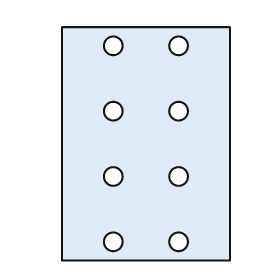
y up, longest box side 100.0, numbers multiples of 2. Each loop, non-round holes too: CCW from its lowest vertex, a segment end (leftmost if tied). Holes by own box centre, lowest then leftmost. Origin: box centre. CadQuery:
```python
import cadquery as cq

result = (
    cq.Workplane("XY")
    .moveTo(-36.0, -50.0)
    .lineTo(36.0, -50.0)
    .lineTo(36.0, 50.0)
    .lineTo(-36.0, 50.0)
    .close()
    .moveTo(-14.0, -42.0)
    .circle(4.0)
    .moveTo(14.0, -42.0)
    .circle(4.0)
    .moveTo(-14.0, -14.0)
    .circle(4.0)
    .moveTo(14.0, -14.0)
    .circle(4.0)
    .moveTo(-14.0, 14.0)
    .circle(4.0)
    .moveTo(14.0, 14.0)
    .circle(4.0)
    .moveTo(-14.0, 42.0)
    .circle(4.0)
    .moveTo(14.0, 42.0)
    .circle(4.0)
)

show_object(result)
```